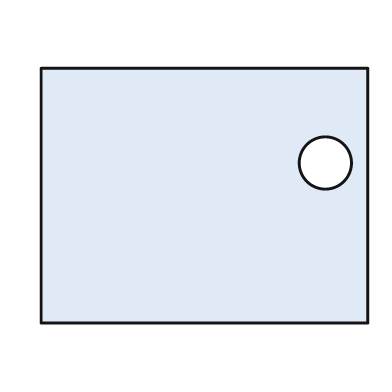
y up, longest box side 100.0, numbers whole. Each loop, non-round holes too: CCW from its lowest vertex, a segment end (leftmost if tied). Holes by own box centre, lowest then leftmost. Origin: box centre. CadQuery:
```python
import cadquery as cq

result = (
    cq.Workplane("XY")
    .moveTo(-50.0, -39.0)
    .lineTo(50.0, -39.0)
    .lineTo(50.0, 39.0)
    .lineTo(-50.0, 39.0)
    .close()
    .moveTo(37.0, 10.0)
    .circle(8.0)
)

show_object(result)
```